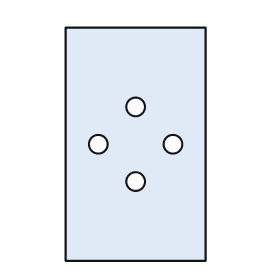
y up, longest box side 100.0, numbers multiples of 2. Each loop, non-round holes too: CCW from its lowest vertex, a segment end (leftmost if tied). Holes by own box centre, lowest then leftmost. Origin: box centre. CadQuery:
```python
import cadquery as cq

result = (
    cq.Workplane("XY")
    .moveTo(-30.0, -50.0)
    .lineTo(30.0, -50.0)
    .lineTo(30.0, 50.0)
    .lineTo(-30.0, 50.0)
    .close()
    .moveTo(0.0, -16.0)
    .circle(4.0)
    .moveTo(-16.0, 0.0)
    .circle(4.0)
    .moveTo(16.0, 0.0)
    .circle(4.0)
    .moveTo(0.0, 16.0)
    .circle(4.0)
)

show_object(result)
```